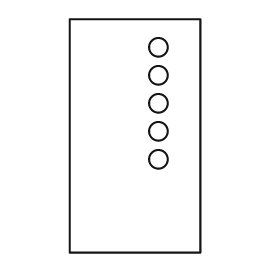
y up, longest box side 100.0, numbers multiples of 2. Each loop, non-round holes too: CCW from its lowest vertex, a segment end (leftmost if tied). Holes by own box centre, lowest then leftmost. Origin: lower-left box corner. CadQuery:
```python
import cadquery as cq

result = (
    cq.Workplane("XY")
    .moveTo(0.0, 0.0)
    .lineTo(56.0, 0.0)
    .lineTo(56.0, 100.0)
    .lineTo(0.0, 100.0)
    .close()
    .moveTo(38.0, 40.0)
    .circle(4.0)
    .moveTo(38.0, 52.0)
    .circle(4.0)
    .moveTo(38.0, 64.0)
    .circle(4.0)
    .moveTo(38.0, 76.0)
    .circle(4.0)
    .moveTo(38.0, 88.0)
    .circle(4.0)
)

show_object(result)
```